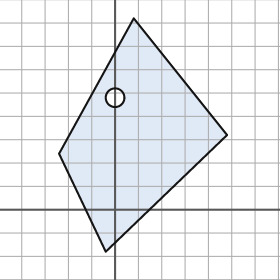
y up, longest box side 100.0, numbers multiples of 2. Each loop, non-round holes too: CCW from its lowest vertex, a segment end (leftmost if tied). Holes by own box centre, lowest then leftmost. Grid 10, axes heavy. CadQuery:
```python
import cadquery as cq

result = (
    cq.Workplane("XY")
    .moveTo(-4.0, -18.0)
    .lineTo(48.0, 32.0)
    .lineTo(8.0, 82.0)
    .lineTo(-24.0, 24.0)
    .close()
    .moveTo(0.0, 48.0)
    .circle(4.0)
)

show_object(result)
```